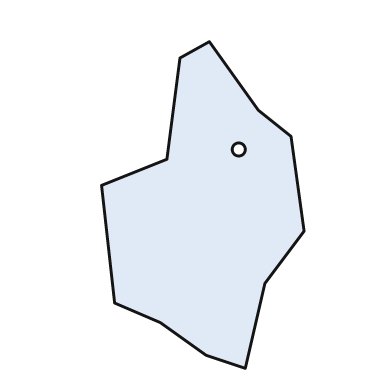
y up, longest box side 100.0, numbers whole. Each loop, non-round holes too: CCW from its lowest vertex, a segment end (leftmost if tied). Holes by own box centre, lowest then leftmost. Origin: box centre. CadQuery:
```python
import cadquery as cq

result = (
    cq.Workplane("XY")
    .moveTo(13.0, -50.0)
    .lineTo(19.0, -24.0)
    .lineTo(31.0, -8.0)
    .lineTo(27.0, 21.0)
    .lineTo(17.0, 29.0)
    .lineTo(2.0, 50.0)
    .lineTo(-7.0, 45.0)
    .lineTo(-11.0, 14.0)
    .lineTo(-31.0, 6.0)
    .lineTo(-27.0, -30.0)
    .lineTo(-13.0, -36.0)
    .lineTo(1.0, -46.0)
    .close()
    .moveTo(11.0, 17.0)
    .circle(2.0)
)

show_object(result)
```